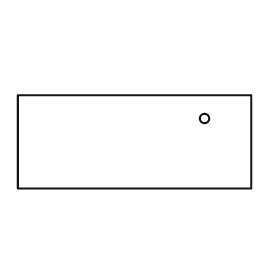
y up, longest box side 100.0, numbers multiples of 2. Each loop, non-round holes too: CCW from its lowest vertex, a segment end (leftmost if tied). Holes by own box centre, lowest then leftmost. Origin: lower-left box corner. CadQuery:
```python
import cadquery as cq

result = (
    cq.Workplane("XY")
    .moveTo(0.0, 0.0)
    .lineTo(100.0, 0.0)
    .lineTo(100.0, 40.0)
    .lineTo(0.0, 40.0)
    .close()
    .moveTo(80.0, 30.0)
    .circle(2.0)
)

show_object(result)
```